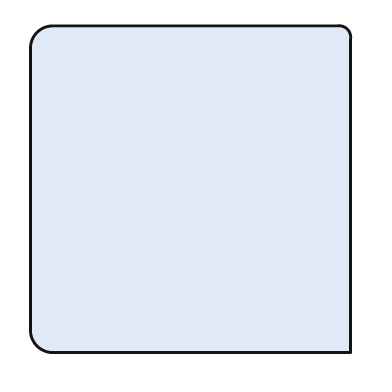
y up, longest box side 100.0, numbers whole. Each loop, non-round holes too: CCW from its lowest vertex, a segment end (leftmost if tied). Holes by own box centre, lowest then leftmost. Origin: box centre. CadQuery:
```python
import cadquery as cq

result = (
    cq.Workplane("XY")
    .moveTo(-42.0, -50.0)
    .lineTo(49.0, -50.0)
    .lineTo(49.0, 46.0)
    .threePointArc((48.0, 49.0), (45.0, 50.0))
    .lineTo(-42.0, 50.0)
    .threePointArc((-47.0, 48.0), (-49.0, 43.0))
    .lineTo(-49.0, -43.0)
    .threePointArc((-47.0, -48.0), (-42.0, -50.0))
    .close()
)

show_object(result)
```